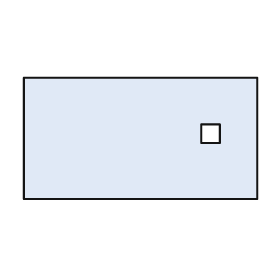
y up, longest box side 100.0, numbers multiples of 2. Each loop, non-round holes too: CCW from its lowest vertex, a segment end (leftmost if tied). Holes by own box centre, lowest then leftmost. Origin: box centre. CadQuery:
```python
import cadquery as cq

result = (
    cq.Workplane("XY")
    .moveTo(-50.0, -26.0)
    .lineTo(50.0, -26.0)
    .lineTo(50.0, 26.0)
    .lineTo(-50.0, 26.0)
    .close()
    .moveTo(26.0, -2.0)
    .lineTo(34.0, -2.0)
    .lineTo(34.0, 6.0)
    .lineTo(26.0, 6.0)
    .close()
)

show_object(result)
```